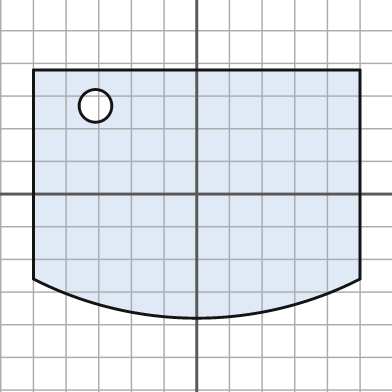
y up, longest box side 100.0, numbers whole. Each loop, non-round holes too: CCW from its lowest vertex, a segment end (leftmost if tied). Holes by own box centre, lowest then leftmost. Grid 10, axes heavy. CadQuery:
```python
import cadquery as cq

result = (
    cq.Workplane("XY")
    .moveTo(-50.0, -26.0)
    .threePointArc((0.0, -38.0), (50.0, -26.0))
    .lineTo(50.0, 38.0)
    .lineTo(-50.0, 38.0)
    .close()
    .moveTo(-31.0, 27.0)
    .circle(5.0)
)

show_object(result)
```